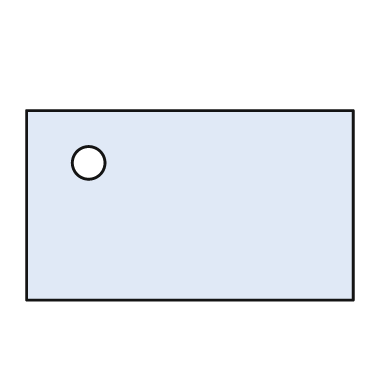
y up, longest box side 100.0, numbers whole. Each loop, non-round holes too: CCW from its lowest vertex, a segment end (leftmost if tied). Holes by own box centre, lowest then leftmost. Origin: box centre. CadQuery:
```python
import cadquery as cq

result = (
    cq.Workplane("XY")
    .moveTo(-50.0, -29.0)
    .lineTo(50.0, -29.0)
    .lineTo(50.0, 29.0)
    .lineTo(-50.0, 29.0)
    .close()
    .moveTo(-31.0, 13.0)
    .circle(5.0)
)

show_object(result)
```